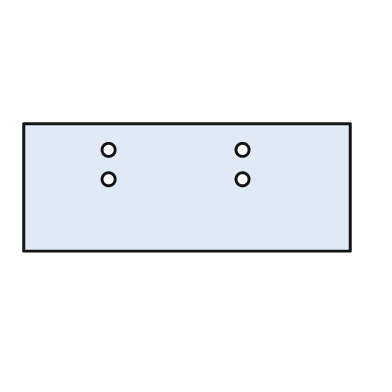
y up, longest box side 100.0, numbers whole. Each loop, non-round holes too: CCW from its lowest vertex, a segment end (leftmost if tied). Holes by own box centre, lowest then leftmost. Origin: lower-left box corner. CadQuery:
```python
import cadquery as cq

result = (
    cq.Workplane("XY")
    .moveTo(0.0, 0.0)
    .lineTo(100.0, 0.0)
    .lineTo(100.0, 39.0)
    .lineTo(0.0, 39.0)
    .close()
    .moveTo(26.0, 22.0)
    .circle(2.0)
    .moveTo(67.0, 22.0)
    .circle(2.0)
    .moveTo(26.0, 31.0)
    .circle(2.0)
    .moveTo(67.0, 31.0)
    .circle(2.0)
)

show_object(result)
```